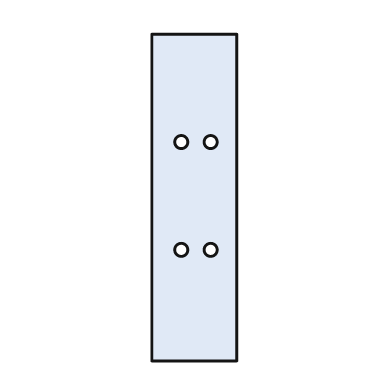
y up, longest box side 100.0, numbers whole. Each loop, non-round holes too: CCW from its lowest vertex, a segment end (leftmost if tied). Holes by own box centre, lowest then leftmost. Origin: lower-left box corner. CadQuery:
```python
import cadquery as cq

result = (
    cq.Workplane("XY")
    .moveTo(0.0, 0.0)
    .lineTo(26.0, 0.0)
    .lineTo(26.0, 100.0)
    .lineTo(0.0, 100.0)
    .close()
    .moveTo(9.0, 34.0)
    .circle(2.0)
    .moveTo(18.0, 34.0)
    .circle(2.0)
    .moveTo(9.0, 67.0)
    .circle(2.0)
    .moveTo(18.0, 67.0)
    .circle(2.0)
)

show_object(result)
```